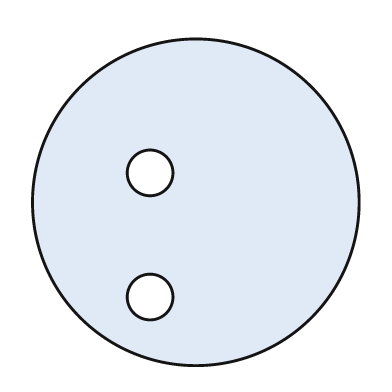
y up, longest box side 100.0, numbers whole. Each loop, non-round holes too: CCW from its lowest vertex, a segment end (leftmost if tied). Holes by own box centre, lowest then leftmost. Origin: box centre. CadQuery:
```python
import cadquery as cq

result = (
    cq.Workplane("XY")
    .moveTo(0.0, 0.0)
    .circle(50.0)
    .moveTo(-14.0, -29.0)
    .circle(7.0)
    .moveTo(-14.0, 9.0)
    .circle(7.0)
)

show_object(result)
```